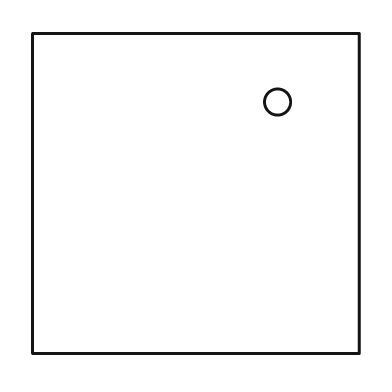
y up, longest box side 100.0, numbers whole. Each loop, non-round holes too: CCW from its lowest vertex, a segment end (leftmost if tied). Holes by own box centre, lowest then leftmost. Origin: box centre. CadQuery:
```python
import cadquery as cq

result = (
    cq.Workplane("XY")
    .moveTo(-50.0, -49.0)
    .lineTo(50.0, -49.0)
    .lineTo(50.0, 49.0)
    .lineTo(-50.0, 49.0)
    .close()
    .moveTo(25.0, 28.0)
    .circle(4.0)
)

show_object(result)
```